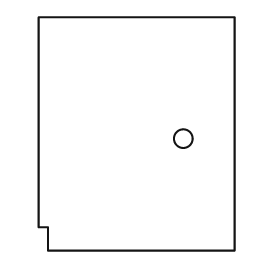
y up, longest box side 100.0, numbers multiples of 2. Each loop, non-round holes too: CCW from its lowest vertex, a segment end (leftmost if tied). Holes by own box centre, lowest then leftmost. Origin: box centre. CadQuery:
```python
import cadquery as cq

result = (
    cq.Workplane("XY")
    .moveTo(-38.0, -50.0)
    .lineTo(42.0, -50.0)
    .lineTo(42.0, 50.0)
    .lineTo(-42.0, 50.0)
    .lineTo(-42.0, -40.0)
    .lineTo(-38.0, -40.0)
    .close()
    .moveTo(20.0, -2.0)
    .circle(4.0)
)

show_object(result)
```